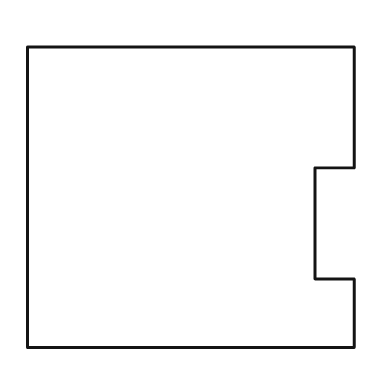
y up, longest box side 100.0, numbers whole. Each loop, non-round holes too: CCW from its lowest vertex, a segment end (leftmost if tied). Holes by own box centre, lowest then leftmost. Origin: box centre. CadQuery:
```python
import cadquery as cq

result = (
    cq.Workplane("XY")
    .moveTo(-50.0, -46.0)
    .lineTo(50.0, -46.0)
    .lineTo(50.0, -25.0)
    .lineTo(38.0, -25.0)
    .lineTo(38.0, 9.0)
    .lineTo(50.0, 9.0)
    .lineTo(50.0, 46.0)
    .lineTo(-50.0, 46.0)
    .close()
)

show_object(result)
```